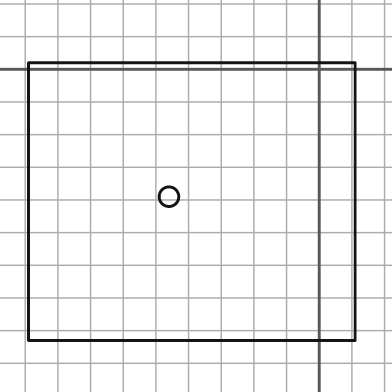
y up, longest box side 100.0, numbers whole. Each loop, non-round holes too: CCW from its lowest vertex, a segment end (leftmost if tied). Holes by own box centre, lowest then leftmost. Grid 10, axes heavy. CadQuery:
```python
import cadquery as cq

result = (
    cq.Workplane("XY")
    .moveTo(-89.0, -83.0)
    .lineTo(11.0, -83.0)
    .lineTo(11.0, 2.0)
    .lineTo(-89.0, 2.0)
    .close()
    .moveTo(-46.0, -39.0)
    .circle(3.0)
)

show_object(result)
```